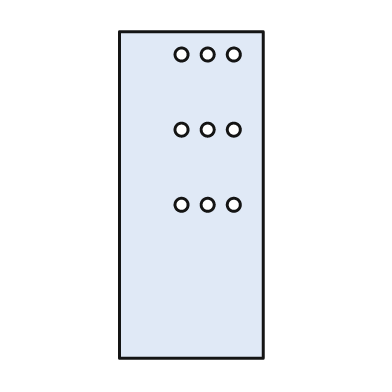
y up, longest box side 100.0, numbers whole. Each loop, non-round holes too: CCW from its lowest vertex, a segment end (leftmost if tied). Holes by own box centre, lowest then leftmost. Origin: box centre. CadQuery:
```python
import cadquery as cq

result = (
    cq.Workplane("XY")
    .moveTo(-22.0, -50.0)
    .lineTo(22.0, -50.0)
    .lineTo(22.0, 50.0)
    .lineTo(-22.0, 50.0)
    .close()
    .moveTo(-3.0, -3.0)
    .circle(2.0)
    .moveTo(5.0, -3.0)
    .circle(2.0)
    .moveTo(13.0, -3.0)
    .circle(2.0)
    .moveTo(-3.0, 20.0)
    .circle(2.0)
    .moveTo(5.0, 20.0)
    .circle(2.0)
    .moveTo(13.0, 20.0)
    .circle(2.0)
    .moveTo(-3.0, 43.0)
    .circle(2.0)
    .moveTo(5.0, 43.0)
    .circle(2.0)
    .moveTo(13.0, 43.0)
    .circle(2.0)
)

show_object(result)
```